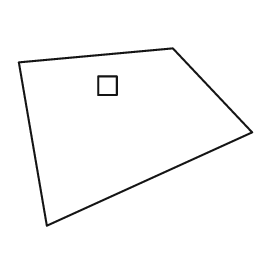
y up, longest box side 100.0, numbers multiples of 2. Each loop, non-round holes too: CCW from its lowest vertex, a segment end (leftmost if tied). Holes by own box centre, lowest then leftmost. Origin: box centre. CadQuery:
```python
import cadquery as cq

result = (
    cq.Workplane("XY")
    .moveTo(-38.0, -38.0)
    .lineTo(50.0, 2.0)
    .lineTo(16.0, 38.0)
    .lineTo(-50.0, 32.0)
    .close()
    .moveTo(-16.0, 18.0)
    .lineTo(-8.0, 18.0)
    .lineTo(-8.0, 26.0)
    .lineTo(-16.0, 26.0)
    .close()
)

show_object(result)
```